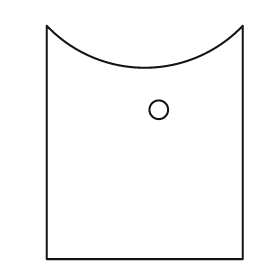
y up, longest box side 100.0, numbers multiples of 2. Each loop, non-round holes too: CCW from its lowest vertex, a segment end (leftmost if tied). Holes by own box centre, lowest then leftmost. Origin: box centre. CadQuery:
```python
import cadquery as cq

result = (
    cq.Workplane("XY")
    .moveTo(-42.0, -50.0)
    .lineTo(42.0, -50.0)
    .lineTo(42.0, 50.0)
    .threePointArc((0.0, 32.0), (-42.0, 50.0))
    .close()
    .moveTo(6.0, 14.0)
    .circle(4.0)
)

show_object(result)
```